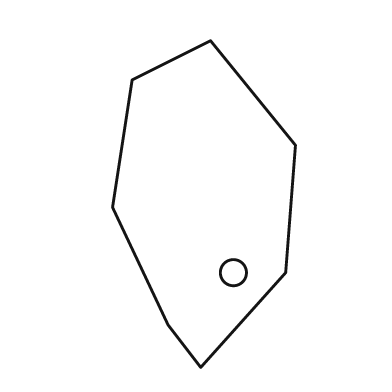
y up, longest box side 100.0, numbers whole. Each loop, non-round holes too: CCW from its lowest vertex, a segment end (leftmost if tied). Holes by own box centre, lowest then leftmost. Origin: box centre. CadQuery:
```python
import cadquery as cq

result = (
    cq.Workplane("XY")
    .moveTo(-1.0, -50.0)
    .lineTo(25.0, -21.0)
    .lineTo(28.0, 18.0)
    .lineTo(2.0, 50.0)
    .lineTo(-22.0, 38.0)
    .lineTo(-28.0, -1.0)
    .lineTo(-11.0, -37.0)
    .close()
    .moveTo(9.0, -21.0)
    .circle(4.0)
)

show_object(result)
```